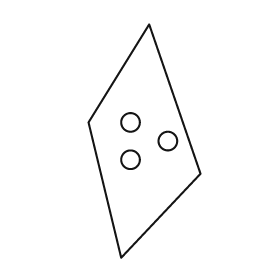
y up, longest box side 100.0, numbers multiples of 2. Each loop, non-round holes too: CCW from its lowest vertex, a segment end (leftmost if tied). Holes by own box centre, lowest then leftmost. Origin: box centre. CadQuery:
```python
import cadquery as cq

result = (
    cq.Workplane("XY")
    .moveTo(-10.0, -50.0)
    .lineTo(24.0, -14.0)
    .lineTo(2.0, 50.0)
    .lineTo(-24.0, 8.0)
    .close()
    .moveTo(-6.0, -8.0)
    .circle(4.0)
    .moveTo(10.0, 0.0)
    .circle(4.0)
    .moveTo(-6.0, 8.0)
    .circle(4.0)
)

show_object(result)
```